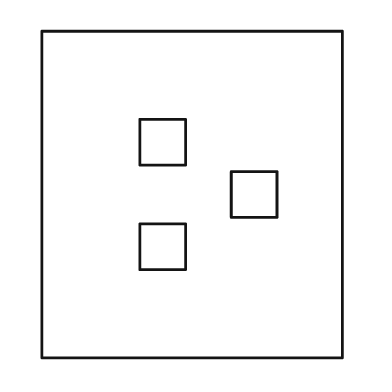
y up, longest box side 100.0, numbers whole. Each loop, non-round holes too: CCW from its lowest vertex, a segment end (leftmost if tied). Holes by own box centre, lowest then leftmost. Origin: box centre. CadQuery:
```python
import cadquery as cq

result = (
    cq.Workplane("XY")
    .moveTo(-46.0, -50.0)
    .lineTo(46.0, -50.0)
    .lineTo(46.0, 50.0)
    .lineTo(-46.0, 50.0)
    .close()
    .moveTo(-16.0, -23.0)
    .lineTo(-2.0, -23.0)
    .lineTo(-2.0, -9.0)
    .lineTo(-16.0, -9.0)
    .close()
    .moveTo(12.0, -7.0)
    .lineTo(26.0, -7.0)
    .lineTo(26.0, 7.0)
    .lineTo(12.0, 7.0)
    .close()
    .moveTo(-16.0, 9.0)
    .lineTo(-2.0, 9.0)
    .lineTo(-2.0, 23.0)
    .lineTo(-16.0, 23.0)
    .close()
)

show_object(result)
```